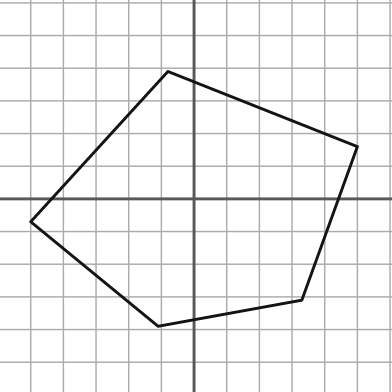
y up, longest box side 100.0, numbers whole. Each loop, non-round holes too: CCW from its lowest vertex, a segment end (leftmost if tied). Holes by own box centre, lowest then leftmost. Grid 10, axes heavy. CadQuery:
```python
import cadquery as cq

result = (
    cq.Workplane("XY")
    .moveTo(-11.0, -39.0)
    .lineTo(33.0, -31.0)
    .lineTo(50.0, 16.0)
    .lineTo(-8.0, 39.0)
    .lineTo(-50.0, -7.0)
    .close()
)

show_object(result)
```